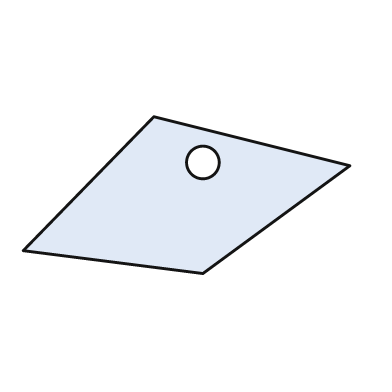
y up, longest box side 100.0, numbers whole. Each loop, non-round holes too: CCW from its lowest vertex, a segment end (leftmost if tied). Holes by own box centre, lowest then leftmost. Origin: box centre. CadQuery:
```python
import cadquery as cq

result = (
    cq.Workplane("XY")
    .moveTo(5.0, -24.0)
    .lineTo(50.0, 9.0)
    .lineTo(-10.0, 24.0)
    .lineTo(-50.0, -17.0)
    .close()
    .moveTo(5.0, 10.0)
    .circle(5.0)
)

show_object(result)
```